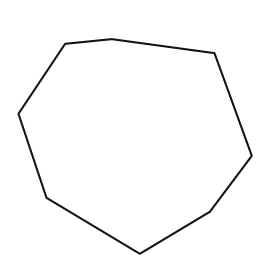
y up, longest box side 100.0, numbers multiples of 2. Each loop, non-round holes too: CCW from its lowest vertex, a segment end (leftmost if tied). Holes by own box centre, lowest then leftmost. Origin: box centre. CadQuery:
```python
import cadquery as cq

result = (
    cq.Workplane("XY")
    .moveTo(2.0, -46.0)
    .lineTo(32.0, -28.0)
    .lineTo(50.0, -4.0)
    .lineTo(34.0, 40.0)
    .lineTo(-10.0, 46.0)
    .lineTo(-30.0, 44.0)
    .lineTo(-50.0, 14.0)
    .lineTo(-38.0, -22.0)
    .close()
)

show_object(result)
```